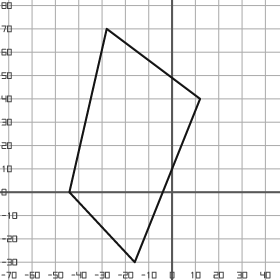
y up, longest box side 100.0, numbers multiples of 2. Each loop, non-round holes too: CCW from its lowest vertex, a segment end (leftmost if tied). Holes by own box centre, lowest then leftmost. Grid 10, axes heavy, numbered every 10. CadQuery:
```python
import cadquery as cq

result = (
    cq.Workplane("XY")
    .moveTo(-16.0, -30.0)
    .lineTo(12.0, 40.0)
    .lineTo(-28.0, 70.0)
    .lineTo(-44.0, 0.0)
    .close()
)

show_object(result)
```